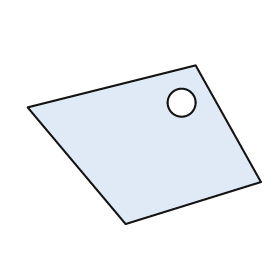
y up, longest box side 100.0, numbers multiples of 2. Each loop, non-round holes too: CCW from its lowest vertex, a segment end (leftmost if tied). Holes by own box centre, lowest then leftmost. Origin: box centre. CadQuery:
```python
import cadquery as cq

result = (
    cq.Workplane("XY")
    .moveTo(-8.0, -34.0)
    .lineTo(50.0, -16.0)
    .lineTo(22.0, 34.0)
    .lineTo(-50.0, 16.0)
    .close()
    .moveTo(16.0, 18.0)
    .circle(6.0)
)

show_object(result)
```